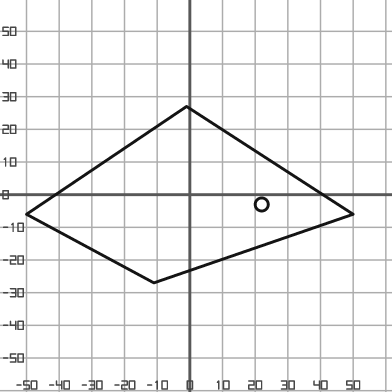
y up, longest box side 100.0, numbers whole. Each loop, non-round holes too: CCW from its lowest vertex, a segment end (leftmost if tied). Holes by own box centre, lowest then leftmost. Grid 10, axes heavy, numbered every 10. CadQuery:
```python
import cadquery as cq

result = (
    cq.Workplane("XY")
    .moveTo(-11.0, -27.0)
    .lineTo(50.0, -6.0)
    .lineTo(-1.0, 27.0)
    .lineTo(-50.0, -6.0)
    .close()
    .moveTo(22.0, -3.0)
    .circle(2.0)
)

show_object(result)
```